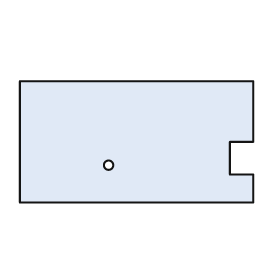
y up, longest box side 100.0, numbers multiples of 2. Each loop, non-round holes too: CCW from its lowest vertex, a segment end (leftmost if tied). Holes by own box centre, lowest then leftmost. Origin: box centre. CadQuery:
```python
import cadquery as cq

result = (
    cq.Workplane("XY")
    .moveTo(-50.0, -26.0)
    .lineTo(50.0, -26.0)
    .lineTo(50.0, -14.0)
    .lineTo(40.0, -14.0)
    .lineTo(40.0, 0.0)
    .lineTo(50.0, 0.0)
    .lineTo(50.0, 26.0)
    .lineTo(-50.0, 26.0)
    .close()
    .moveTo(-12.0, -10.0)
    .circle(2.0)
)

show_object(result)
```